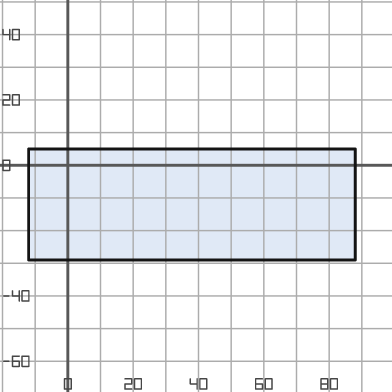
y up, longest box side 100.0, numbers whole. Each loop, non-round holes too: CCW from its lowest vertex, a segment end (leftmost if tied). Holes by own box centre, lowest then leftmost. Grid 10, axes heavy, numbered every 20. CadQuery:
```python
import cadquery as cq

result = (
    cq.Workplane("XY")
    .moveTo(-12.0, -29.0)
    .lineTo(88.0, -29.0)
    .lineTo(88.0, 5.0)
    .lineTo(-12.0, 5.0)
    .close()
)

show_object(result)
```